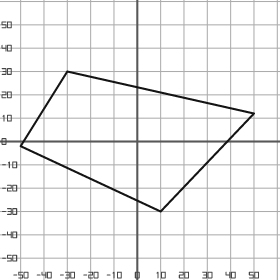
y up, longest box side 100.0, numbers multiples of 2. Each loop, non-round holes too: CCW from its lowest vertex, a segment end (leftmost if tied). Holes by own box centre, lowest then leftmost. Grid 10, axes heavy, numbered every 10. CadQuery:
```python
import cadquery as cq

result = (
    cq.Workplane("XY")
    .moveTo(10.0, -30.0)
    .lineTo(50.0, 12.0)
    .lineTo(-30.0, 30.0)
    .lineTo(-50.0, -2.0)
    .close()
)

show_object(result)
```